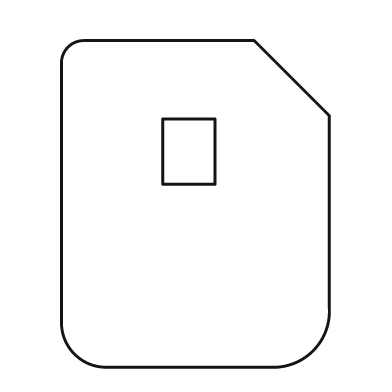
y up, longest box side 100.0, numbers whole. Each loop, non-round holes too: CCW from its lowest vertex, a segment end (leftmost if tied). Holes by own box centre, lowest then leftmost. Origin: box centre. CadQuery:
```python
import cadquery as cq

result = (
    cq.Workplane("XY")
    .moveTo(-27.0, -50.0)
    .lineTo(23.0, -50.0)
    .threePointArc((36.0, -45.0), (41.0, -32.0))
    .lineTo(41.0, 27.0)
    .lineTo(18.0, 50.0)
    .lineTo(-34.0, 50.0)
    .threePointArc((-39.0, 48.0), (-41.0, 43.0))
    .lineTo(-41.0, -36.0)
    .threePointArc((-37.0, -46.0), (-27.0, -50.0))
    .close()
    .moveTo(-10.0, 6.0)
    .lineTo(6.0, 6.0)
    .lineTo(6.0, 26.0)
    .lineTo(-10.0, 26.0)
    .close()
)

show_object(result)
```